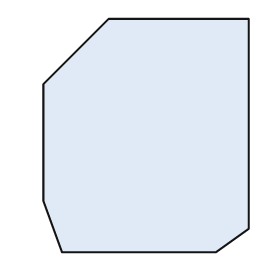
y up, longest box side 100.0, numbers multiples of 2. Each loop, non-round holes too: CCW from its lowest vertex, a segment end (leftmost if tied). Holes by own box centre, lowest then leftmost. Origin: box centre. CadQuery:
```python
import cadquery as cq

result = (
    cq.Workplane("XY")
    .moveTo(-36.0, -50.0)
    .lineTo(30.0, -50.0)
    .lineTo(44.0, -40.0)
    .lineTo(44.0, 50.0)
    .lineTo(-16.0, 50.0)
    .lineTo(-44.0, 22.0)
    .lineTo(-44.0, -28.0)
    .close()
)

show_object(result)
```